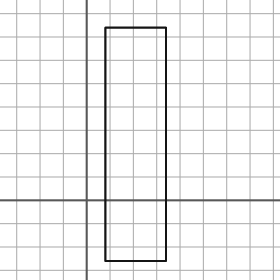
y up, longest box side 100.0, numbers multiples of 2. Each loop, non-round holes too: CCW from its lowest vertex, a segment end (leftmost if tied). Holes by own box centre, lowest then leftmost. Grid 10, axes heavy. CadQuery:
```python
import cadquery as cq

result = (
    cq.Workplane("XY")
    .moveTo(8.0, -26.0)
    .lineTo(34.0, -26.0)
    .lineTo(34.0, 74.0)
    .lineTo(8.0, 74.0)
    .close()
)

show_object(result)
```